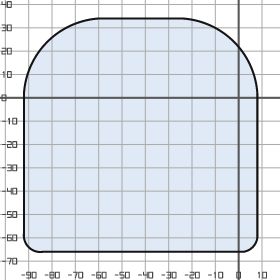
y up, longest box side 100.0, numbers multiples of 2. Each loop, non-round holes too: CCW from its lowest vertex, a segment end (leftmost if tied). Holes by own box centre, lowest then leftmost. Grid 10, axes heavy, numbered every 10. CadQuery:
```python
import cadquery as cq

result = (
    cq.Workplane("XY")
    .moveTo(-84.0, -66.0)
    .lineTo(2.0, -66.0)
    .threePointArc((6.0, -64.0), (8.0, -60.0))
    .lineTo(8.0, 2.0)
    .threePointArc((-2.0, 24.0), (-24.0, 34.0))
    .lineTo(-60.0, 34.0)
    .threePointArc((-82.0, 24.0), (-92.0, 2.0))
    .lineTo(-92.0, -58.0)
    .threePointArc((-90.0, -64.0), (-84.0, -66.0))
    .close()
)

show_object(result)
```